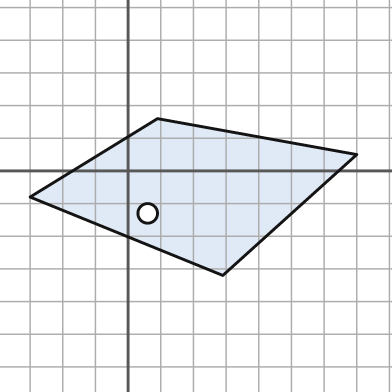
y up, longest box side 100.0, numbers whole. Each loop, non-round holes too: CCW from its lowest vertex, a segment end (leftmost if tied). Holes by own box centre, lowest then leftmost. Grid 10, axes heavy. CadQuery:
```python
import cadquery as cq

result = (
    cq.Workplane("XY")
    .moveTo(29.0, -32.0)
    .lineTo(70.0, 5.0)
    .lineTo(9.0, 16.0)
    .lineTo(-30.0, -8.0)
    .close()
    .moveTo(6.0, -13.0)
    .circle(3.0)
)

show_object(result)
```